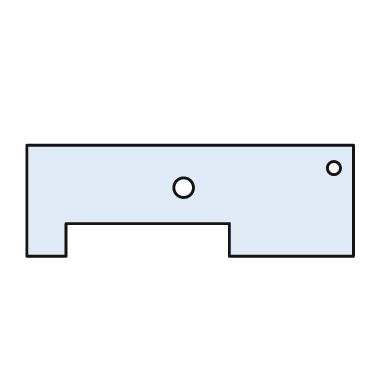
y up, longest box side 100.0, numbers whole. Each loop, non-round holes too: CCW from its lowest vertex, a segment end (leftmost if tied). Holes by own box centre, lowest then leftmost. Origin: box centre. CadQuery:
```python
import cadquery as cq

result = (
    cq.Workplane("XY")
    .moveTo(-50.0, -17.0)
    .lineTo(-38.0, -17.0)
    .lineTo(-38.0, -7.0)
    .lineTo(12.0, -7.0)
    .lineTo(12.0, -17.0)
    .lineTo(50.0, -17.0)
    .lineTo(50.0, 17.0)
    .lineTo(-50.0, 17.0)
    .close()
    .moveTo(-2.0, 4.0)
    .circle(3.0)
    .moveTo(44.0, 10.0)
    .circle(2.0)
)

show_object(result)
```